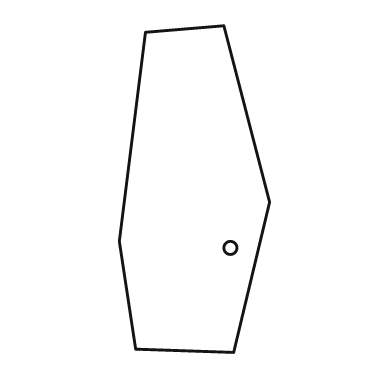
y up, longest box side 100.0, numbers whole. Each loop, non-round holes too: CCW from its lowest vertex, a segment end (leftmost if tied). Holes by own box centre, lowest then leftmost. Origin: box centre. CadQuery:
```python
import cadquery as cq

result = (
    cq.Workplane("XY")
    .moveTo(12.0, -50.0)
    .lineTo(23.0, -4.0)
    .lineTo(9.0, 50.0)
    .lineTo(-15.0, 48.0)
    .lineTo(-23.0, -16.0)
    .lineTo(-18.0, -49.0)
    .close()
    .moveTo(11.0, -18.0)
    .circle(2.0)
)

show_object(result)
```